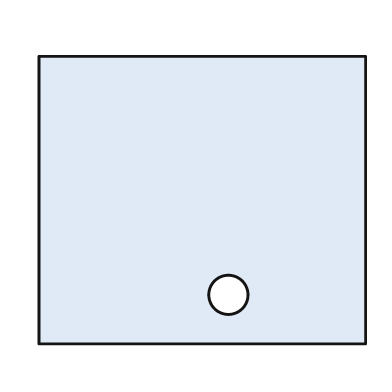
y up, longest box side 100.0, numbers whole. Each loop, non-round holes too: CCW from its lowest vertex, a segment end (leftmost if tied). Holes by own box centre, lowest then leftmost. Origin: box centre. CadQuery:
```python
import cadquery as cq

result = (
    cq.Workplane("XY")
    .moveTo(-50.0, -44.0)
    .lineTo(50.0, -44.0)
    .lineTo(50.0, 44.0)
    .lineTo(-50.0, 44.0)
    .close()
    .moveTo(8.0, -29.0)
    .circle(6.0)
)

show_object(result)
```